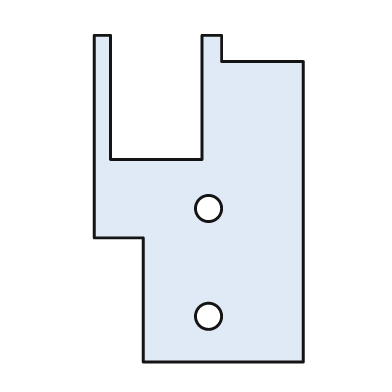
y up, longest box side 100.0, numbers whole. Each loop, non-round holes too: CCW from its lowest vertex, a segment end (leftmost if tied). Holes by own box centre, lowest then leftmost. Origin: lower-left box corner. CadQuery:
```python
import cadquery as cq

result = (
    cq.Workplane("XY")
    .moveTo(15.0, 0.0)
    .lineTo(64.0, 0.0)
    .lineTo(64.0, 92.0)
    .lineTo(39.0, 92.0)
    .lineTo(39.0, 100.0)
    .lineTo(33.0, 100.0)
    .lineTo(33.0, 62.0)
    .lineTo(5.0, 62.0)
    .lineTo(5.0, 100.0)
    .lineTo(0.0, 100.0)
    .lineTo(0.0, 38.0)
    .lineTo(15.0, 38.0)
    .close()
    .moveTo(35.0, 14.0)
    .circle(4.0)
    .moveTo(35.0, 47.0)
    .circle(4.0)
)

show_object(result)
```